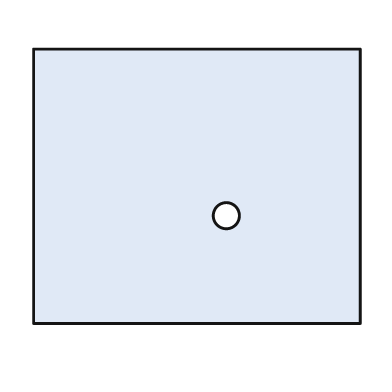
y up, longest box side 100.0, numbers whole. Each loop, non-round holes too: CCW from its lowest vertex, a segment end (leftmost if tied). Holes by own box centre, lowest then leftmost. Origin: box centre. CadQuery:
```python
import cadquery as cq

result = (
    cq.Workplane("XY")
    .moveTo(-50.0, -42.0)
    .lineTo(50.0, -42.0)
    .lineTo(50.0, 42.0)
    .lineTo(-50.0, 42.0)
    .close()
    .moveTo(9.0, -9.0)
    .circle(4.0)
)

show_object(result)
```